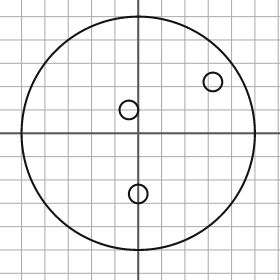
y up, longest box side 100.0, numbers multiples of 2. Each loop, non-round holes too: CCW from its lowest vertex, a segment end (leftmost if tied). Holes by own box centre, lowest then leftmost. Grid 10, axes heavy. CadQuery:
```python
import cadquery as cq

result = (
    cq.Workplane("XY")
    .moveTo(0.0, 0.0)
    .circle(50.0)
    .moveTo(0.0, -26.0)
    .circle(4.0)
    .moveTo(-4.0, 10.0)
    .circle(4.0)
    .moveTo(32.0, 22.0)
    .circle(4.0)
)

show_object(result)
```